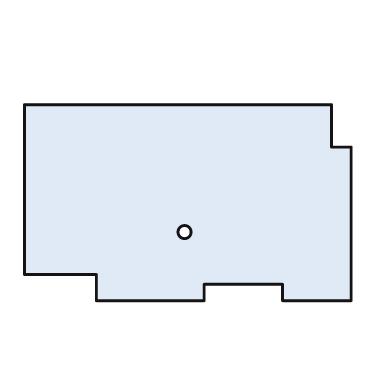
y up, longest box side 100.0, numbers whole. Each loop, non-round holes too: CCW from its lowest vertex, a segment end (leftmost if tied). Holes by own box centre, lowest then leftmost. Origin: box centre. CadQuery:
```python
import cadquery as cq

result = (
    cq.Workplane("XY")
    .moveTo(-28.0, -30.0)
    .lineTo(5.0, -30.0)
    .lineTo(5.0, -25.0)
    .lineTo(29.0, -25.0)
    .lineTo(29.0, -30.0)
    .lineTo(50.0, -30.0)
    .lineTo(50.0, 17.0)
    .lineTo(44.0, 17.0)
    .lineTo(44.0, 30.0)
    .lineTo(-50.0, 30.0)
    .lineTo(-50.0, -22.0)
    .lineTo(-28.0, -22.0)
    .close()
    .moveTo(-1.0, -9.0)
    .circle(2.0)
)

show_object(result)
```